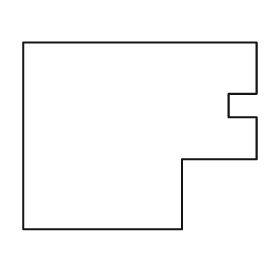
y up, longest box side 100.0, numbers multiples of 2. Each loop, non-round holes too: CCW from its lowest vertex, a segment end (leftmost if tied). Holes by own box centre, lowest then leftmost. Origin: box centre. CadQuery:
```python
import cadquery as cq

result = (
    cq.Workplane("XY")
    .moveTo(-50.0, -40.0)
    .lineTo(18.0, -40.0)
    .lineTo(18.0, -10.0)
    .lineTo(50.0, -10.0)
    .lineTo(50.0, 8.0)
    .lineTo(38.0, 8.0)
    .lineTo(38.0, 18.0)
    .lineTo(50.0, 18.0)
    .lineTo(50.0, 40.0)
    .lineTo(-50.0, 40.0)
    .close()
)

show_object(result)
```